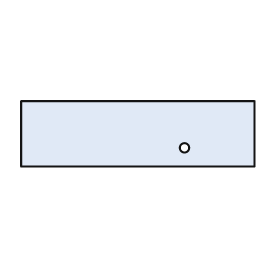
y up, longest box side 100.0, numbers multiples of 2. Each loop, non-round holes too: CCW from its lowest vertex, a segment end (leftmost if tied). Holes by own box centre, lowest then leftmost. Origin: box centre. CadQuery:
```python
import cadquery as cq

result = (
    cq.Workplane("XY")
    .moveTo(-50.0, -14.0)
    .lineTo(50.0, -14.0)
    .lineTo(50.0, 14.0)
    .lineTo(-50.0, 14.0)
    .close()
    .moveTo(20.0, -6.0)
    .circle(2.0)
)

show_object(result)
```